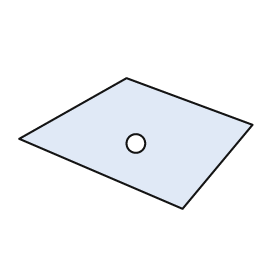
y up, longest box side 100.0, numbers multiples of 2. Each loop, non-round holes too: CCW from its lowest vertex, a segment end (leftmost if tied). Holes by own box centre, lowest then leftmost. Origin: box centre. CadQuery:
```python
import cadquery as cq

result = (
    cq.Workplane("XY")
    .moveTo(20.0, -28.0)
    .lineTo(50.0, 8.0)
    .lineTo(-4.0, 28.0)
    .lineTo(-50.0, 2.0)
    .close()
    .moveTo(0.0, 0.0)
    .circle(4.0)
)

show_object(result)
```